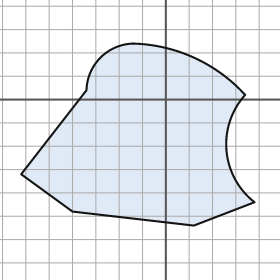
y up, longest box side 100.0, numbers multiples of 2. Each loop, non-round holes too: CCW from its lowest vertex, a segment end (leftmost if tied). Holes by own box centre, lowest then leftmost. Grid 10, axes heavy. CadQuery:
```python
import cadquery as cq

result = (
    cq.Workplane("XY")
    .moveTo(12.0, -54.0)
    .lineTo(38.0, -44.0)
    .threePointArc((26.0, -22.0), (34.0, 2.0))
    .threePointArc((12.0, 18.0), (-14.0, 24.0))
    .threePointArc((-28.0, 18.0), (-34.0, 4.0))
    .lineTo(-62.0, -32.0)
    .lineTo(-40.0, -48.0)
    .close()
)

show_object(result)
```